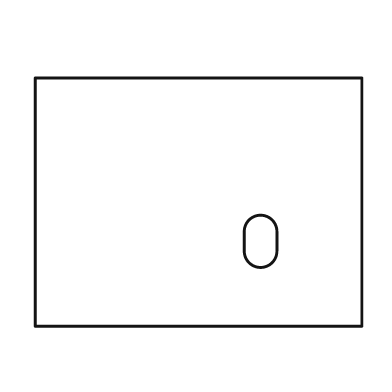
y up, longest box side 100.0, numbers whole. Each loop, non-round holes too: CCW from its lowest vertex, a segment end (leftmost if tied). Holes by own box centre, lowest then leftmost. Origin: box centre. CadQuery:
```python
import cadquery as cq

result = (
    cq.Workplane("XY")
    .moveTo(-50.0, -38.0)
    .lineTo(50.0, -38.0)
    .lineTo(50.0, 38.0)
    .lineTo(-50.0, 38.0)
    .close()
    .moveTo(14.0, -15.0)
    .threePointArc((19.0, -20.0), (24.0, -15.0))
    .lineTo(24.0, -9.0)
    .threePointArc((19.0, -4.0), (14.0, -9.0))
    .close()
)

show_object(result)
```